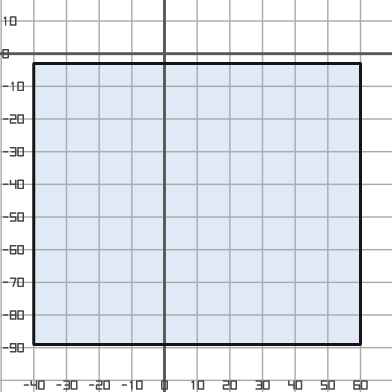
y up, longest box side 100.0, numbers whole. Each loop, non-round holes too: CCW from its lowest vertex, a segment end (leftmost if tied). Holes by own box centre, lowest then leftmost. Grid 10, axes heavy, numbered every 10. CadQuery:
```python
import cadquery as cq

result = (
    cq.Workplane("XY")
    .moveTo(-40.0, -89.0)
    .lineTo(60.0, -89.0)
    .lineTo(60.0, -3.0)
    .lineTo(-40.0, -3.0)
    .close()
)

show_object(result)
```